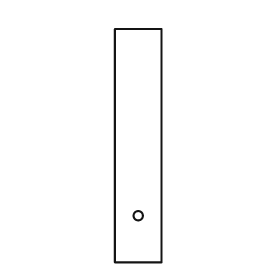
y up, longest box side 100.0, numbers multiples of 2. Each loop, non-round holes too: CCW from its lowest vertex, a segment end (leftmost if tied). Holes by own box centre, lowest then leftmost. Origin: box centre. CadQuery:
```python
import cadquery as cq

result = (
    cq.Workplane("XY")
    .moveTo(-10.0, -50.0)
    .lineTo(10.0, -50.0)
    .lineTo(10.0, 50.0)
    .lineTo(-10.0, 50.0)
    .close()
    .moveTo(0.0, -30.0)
    .circle(2.0)
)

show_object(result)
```